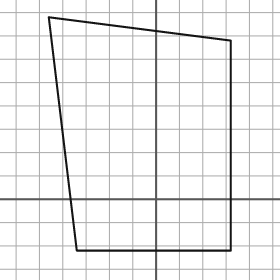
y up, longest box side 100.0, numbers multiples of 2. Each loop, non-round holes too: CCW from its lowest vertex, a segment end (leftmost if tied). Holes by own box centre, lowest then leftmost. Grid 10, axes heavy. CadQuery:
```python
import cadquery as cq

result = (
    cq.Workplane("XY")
    .moveTo(-34.0, -22.0)
    .lineTo(32.0, -22.0)
    .lineTo(32.0, 68.0)
    .lineTo(-46.0, 78.0)
    .close()
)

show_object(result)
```